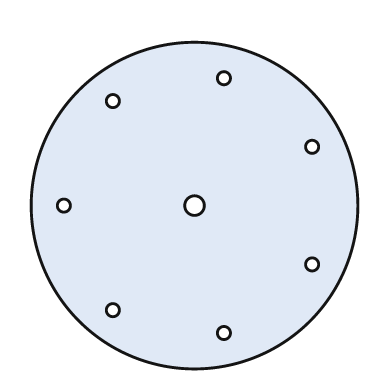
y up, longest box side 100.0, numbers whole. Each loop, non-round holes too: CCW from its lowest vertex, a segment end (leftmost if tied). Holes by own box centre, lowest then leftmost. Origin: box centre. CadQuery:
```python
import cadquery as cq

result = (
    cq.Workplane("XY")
    .moveTo(0.0, 0.0)
    .circle(50.0)
    .moveTo(9.0, -39.0)
    .circle(2.0)
    .moveTo(-25.0, -32.0)
    .circle(2.0)
    .moveTo(36.0, -18.0)
    .circle(2.0)
    .moveTo(-40.0, 0.0)
    .circle(2.0)
    .moveTo(0.0, 0.0)
    .circle(3.0)
    .moveTo(36.0, 18.0)
    .circle(2.0)
    .moveTo(-25.0, 32.0)
    .circle(2.0)
    .moveTo(9.0, 39.0)
    .circle(2.0)
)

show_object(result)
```